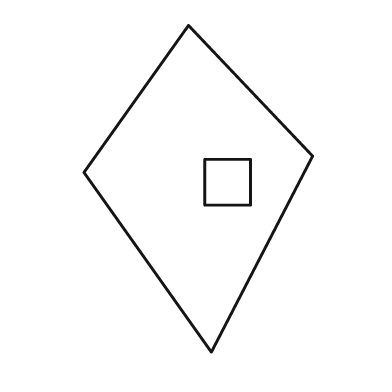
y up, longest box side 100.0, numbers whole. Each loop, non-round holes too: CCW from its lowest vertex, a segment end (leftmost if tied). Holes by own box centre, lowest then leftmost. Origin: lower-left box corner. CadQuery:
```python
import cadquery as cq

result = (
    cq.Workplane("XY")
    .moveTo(39.0, 0.0)
    .lineTo(70.0, 60.0)
    .lineTo(32.0, 100.0)
    .lineTo(0.0, 55.0)
    .close()
    .moveTo(37.0, 45.0)
    .lineTo(51.0, 45.0)
    .lineTo(51.0, 59.0)
    .lineTo(37.0, 59.0)
    .close()
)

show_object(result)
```